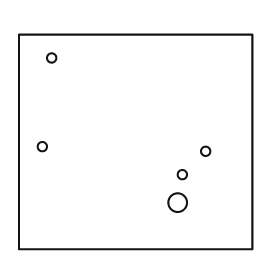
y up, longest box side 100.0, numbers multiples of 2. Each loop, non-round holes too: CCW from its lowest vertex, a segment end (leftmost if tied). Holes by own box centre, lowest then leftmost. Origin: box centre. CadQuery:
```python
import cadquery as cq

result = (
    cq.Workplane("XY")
    .moveTo(-50.0, -46.0)
    .lineTo(50.0, -46.0)
    .lineTo(50.0, 46.0)
    .lineTo(-50.0, 46.0)
    .close()
    .moveTo(18.0, -26.0)
    .circle(4.0)
    .moveTo(20.0, -14.0)
    .circle(2.0)
    .moveTo(30.0, -4.0)
    .circle(2.0)
    .moveTo(-40.0, -2.0)
    .circle(2.0)
    .moveTo(-36.0, 36.0)
    .circle(2.0)
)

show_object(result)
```